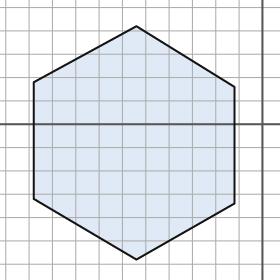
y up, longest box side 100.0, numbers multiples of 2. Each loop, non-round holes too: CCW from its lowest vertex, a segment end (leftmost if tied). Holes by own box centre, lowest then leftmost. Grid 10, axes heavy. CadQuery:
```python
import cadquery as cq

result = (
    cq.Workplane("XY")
    .moveTo(-54.0, -58.0)
    .lineTo(-12.0, -34.0)
    .lineTo(-12.0, 16.0)
    .lineTo(-54.0, 42.0)
    .lineTo(-98.0, 18.0)
    .lineTo(-98.0, -32.0)
    .close()
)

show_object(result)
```